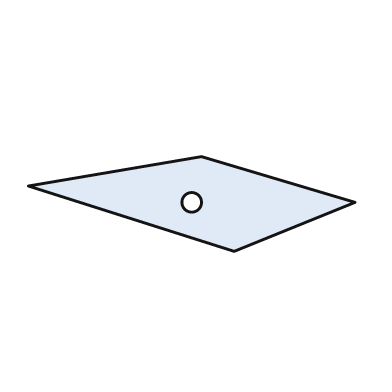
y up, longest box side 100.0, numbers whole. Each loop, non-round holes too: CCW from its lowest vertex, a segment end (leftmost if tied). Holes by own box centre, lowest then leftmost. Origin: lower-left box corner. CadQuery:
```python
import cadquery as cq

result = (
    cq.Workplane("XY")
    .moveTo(63.0, 0.0)
    .lineTo(100.0, 15.0)
    .lineTo(53.0, 29.0)
    .lineTo(0.0, 20.0)
    .close()
    .moveTo(50.0, 15.0)
    .circle(3.0)
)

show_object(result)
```